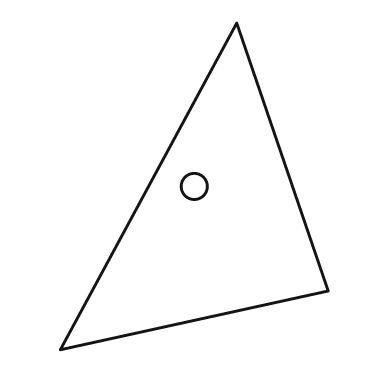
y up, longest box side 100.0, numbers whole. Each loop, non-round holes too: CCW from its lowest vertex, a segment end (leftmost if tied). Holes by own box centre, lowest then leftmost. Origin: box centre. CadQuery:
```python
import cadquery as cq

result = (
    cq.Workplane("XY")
    .moveTo(-41.0, -50.0)
    .lineTo(41.0, -32.0)
    .lineTo(13.0, 50.0)
    .close()
    .moveTo(0.0, 0.0)
    .circle(4.0)
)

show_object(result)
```